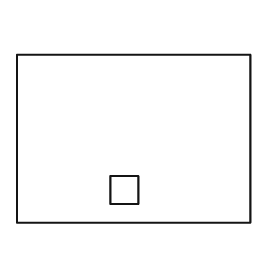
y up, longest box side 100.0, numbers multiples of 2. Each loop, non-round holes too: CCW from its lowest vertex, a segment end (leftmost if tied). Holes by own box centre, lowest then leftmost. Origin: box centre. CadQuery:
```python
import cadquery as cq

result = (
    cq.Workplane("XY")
    .moveTo(-50.0, -36.0)
    .lineTo(50.0, -36.0)
    .lineTo(50.0, 36.0)
    .lineTo(-50.0, 36.0)
    .close()
    .moveTo(-10.0, -28.0)
    .lineTo(2.0, -28.0)
    .lineTo(2.0, -16.0)
    .lineTo(-10.0, -16.0)
    .close()
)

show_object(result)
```